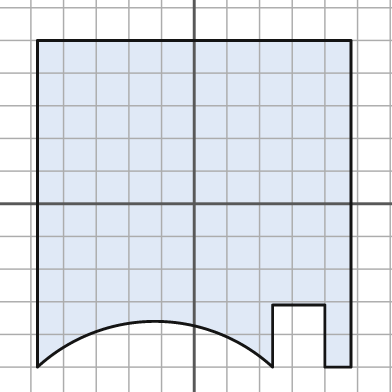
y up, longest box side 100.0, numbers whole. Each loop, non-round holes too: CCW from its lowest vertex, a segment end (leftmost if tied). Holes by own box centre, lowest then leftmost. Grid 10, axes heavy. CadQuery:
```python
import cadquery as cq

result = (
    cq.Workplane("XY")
    .moveTo(-48.0, -50.0)
    .threePointArc((-12.0, -36.0), (24.0, -50.0))
    .lineTo(24.0, -31.0)
    .lineTo(40.0, -31.0)
    .lineTo(40.0, -50.0)
    .lineTo(48.0, -50.0)
    .lineTo(48.0, 50.0)
    .lineTo(-48.0, 50.0)
    .close()
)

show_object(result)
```